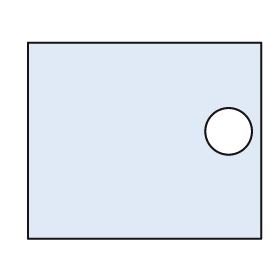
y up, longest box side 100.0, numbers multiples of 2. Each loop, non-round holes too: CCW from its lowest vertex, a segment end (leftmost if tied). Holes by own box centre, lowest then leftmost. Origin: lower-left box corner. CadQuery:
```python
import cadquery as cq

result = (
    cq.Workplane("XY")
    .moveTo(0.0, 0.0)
    .lineTo(100.0, 0.0)
    .lineTo(100.0, 84.0)
    .lineTo(0.0, 84.0)
    .close()
    .moveTo(86.0, 46.0)
    .circle(10.0)
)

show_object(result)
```